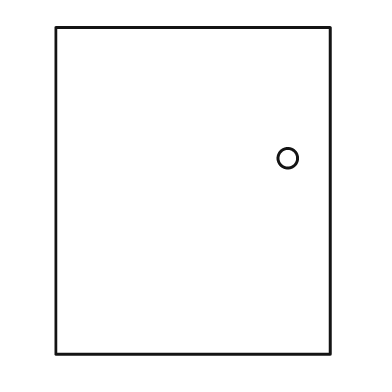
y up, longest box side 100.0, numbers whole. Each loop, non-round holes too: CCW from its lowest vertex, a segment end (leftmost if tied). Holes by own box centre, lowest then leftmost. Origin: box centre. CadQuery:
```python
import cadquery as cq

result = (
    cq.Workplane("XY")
    .moveTo(-42.0, -50.0)
    .lineTo(42.0, -50.0)
    .lineTo(42.0, 50.0)
    .lineTo(-42.0, 50.0)
    .close()
    .moveTo(29.0, 10.0)
    .circle(3.0)
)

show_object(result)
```